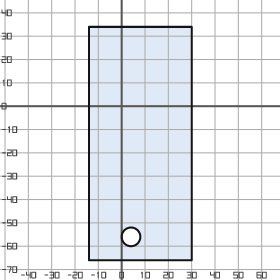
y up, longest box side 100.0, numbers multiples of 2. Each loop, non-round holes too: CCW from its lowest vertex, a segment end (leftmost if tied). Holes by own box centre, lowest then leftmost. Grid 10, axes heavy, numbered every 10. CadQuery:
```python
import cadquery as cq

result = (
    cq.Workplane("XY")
    .moveTo(-14.0, -66.0)
    .lineTo(30.0, -66.0)
    .lineTo(30.0, 34.0)
    .lineTo(-14.0, 34.0)
    .close()
    .moveTo(4.0, -56.0)
    .circle(4.0)
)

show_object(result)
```